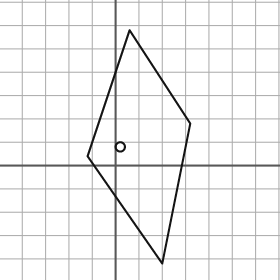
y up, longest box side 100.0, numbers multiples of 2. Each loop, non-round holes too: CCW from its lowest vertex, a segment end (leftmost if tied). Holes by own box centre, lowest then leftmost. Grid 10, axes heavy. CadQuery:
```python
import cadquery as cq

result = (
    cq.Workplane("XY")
    .moveTo(20.0, -42.0)
    .lineTo(32.0, 18.0)
    .lineTo(6.0, 58.0)
    .lineTo(-12.0, 4.0)
    .close()
    .moveTo(2.0, 8.0)
    .circle(2.0)
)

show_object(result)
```